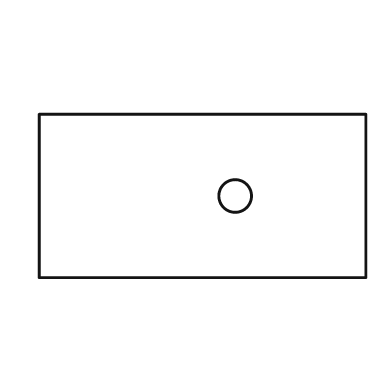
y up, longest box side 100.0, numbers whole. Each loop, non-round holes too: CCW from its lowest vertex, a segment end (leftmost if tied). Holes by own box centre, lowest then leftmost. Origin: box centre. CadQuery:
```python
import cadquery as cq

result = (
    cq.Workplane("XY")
    .moveTo(-50.0, -25.0)
    .lineTo(50.0, -25.0)
    .lineTo(50.0, 25.0)
    .lineTo(-50.0, 25.0)
    .close()
    .moveTo(10.0, 0.0)
    .circle(5.0)
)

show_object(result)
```